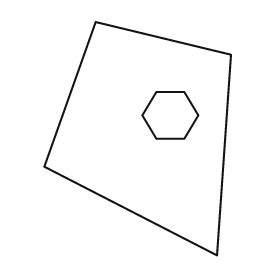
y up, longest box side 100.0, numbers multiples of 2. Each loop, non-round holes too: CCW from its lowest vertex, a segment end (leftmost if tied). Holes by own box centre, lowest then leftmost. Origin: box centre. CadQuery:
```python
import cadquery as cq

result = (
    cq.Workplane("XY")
    .moveTo(34.0, -50.0)
    .lineTo(40.0, 36.0)
    .lineTo(-18.0, 50.0)
    .lineTo(-40.0, -12.0)
    .close()
    .moveTo(8.0, 0.0)
    .lineTo(20.0, 0.0)
    .lineTo(26.0, 10.0)
    .lineTo(20.0, 20.0)
    .lineTo(8.0, 20.0)
    .lineTo(2.0, 10.0)
    .close()
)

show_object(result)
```